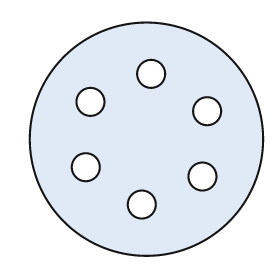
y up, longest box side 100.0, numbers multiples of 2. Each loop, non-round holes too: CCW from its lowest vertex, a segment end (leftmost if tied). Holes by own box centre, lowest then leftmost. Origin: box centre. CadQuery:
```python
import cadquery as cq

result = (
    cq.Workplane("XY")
    .moveTo(0.0, 0.0)
    .circle(50.0)
    .moveTo(-2.0, -28.0)
    .circle(6.0)
    .moveTo(24.0, -16.0)
    .circle(6.0)
    .moveTo(-26.0, -12.0)
    .circle(6.0)
    .moveTo(26.0, 12.0)
    .circle(6.0)
    .moveTo(-24.0, 16.0)
    .circle(6.0)
    .moveTo(2.0, 28.0)
    .circle(6.0)
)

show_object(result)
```